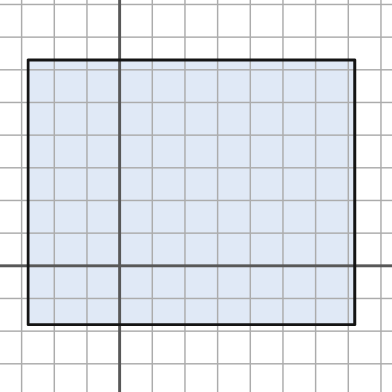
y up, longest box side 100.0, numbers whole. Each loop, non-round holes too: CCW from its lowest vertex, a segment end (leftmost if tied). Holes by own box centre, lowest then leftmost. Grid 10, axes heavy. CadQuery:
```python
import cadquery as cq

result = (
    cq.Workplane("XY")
    .moveTo(-28.0, -18.0)
    .lineTo(72.0, -18.0)
    .lineTo(72.0, 63.0)
    .lineTo(-28.0, 63.0)
    .close()
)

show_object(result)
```